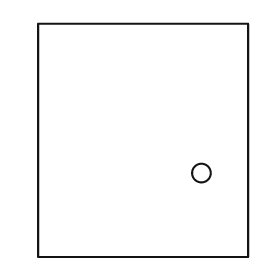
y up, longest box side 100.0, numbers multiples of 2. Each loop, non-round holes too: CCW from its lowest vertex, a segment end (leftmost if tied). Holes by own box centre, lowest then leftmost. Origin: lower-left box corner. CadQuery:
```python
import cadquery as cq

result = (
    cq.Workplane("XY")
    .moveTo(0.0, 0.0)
    .lineTo(90.0, 0.0)
    .lineTo(90.0, 100.0)
    .lineTo(0.0, 100.0)
    .close()
    .moveTo(70.0, 36.0)
    .circle(4.0)
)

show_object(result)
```